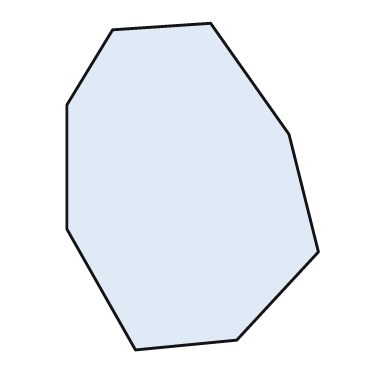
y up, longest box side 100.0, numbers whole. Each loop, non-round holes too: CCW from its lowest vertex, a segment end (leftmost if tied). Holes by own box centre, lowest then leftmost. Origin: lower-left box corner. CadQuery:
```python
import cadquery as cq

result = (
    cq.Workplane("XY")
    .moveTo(21.0, 0.0)
    .lineTo(52.0, 3.0)
    .lineTo(77.0, 30.0)
    .lineTo(68.0, 66.0)
    .lineTo(44.0, 100.0)
    .lineTo(14.0, 98.0)
    .lineTo(0.0, 75.0)
    .lineTo(0.0, 37.0)
    .close()
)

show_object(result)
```